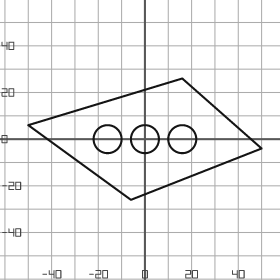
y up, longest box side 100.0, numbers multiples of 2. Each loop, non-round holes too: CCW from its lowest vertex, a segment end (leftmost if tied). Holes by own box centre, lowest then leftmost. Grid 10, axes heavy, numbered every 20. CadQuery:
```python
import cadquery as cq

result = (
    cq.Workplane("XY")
    .moveTo(-6.0, -26.0)
    .lineTo(50.0, -4.0)
    .lineTo(16.0, 26.0)
    .lineTo(-50.0, 6.0)
    .close()
    .moveTo(-16.0, 0.0)
    .circle(6.0)
    .moveTo(0.0, 0.0)
    .circle(6.0)
    .moveTo(16.0, 0.0)
    .circle(6.0)
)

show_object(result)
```